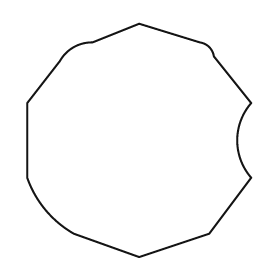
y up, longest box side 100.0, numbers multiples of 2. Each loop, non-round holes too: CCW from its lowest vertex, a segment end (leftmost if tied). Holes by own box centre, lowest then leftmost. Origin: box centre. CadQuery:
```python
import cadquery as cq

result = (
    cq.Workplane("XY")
    .moveTo(0.0, -50.0)
    .lineTo(30.0, -40.0)
    .lineTo(48.0, -16.0)
    .threePointArc((42.0, 0.0), (48.0, 16.0))
    .lineTo(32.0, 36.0)
    .threePointArc((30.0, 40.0), (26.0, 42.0))
    .lineTo(0.0, 50.0)
    .lineTo(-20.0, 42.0)
    .threePointArc((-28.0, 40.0), (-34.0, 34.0))
    .lineTo(-48.0, 16.0)
    .lineTo(-48.0, -16.0)
    .threePointArc((-40.0, -30.0), (-28.0, -40.0))
    .close()
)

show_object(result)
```